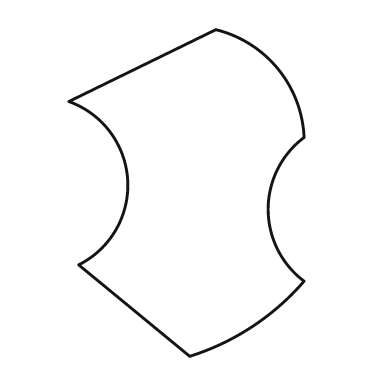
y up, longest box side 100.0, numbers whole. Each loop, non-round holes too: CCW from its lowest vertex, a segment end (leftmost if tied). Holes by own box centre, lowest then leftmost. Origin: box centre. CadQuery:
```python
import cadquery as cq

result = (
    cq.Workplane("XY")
    .moveTo(1.0, -50.0)
    .threePointArc((20.0, -41.0), (36.0, -27.0))
    .threePointArc((25.0, -5.0), (36.0, 17.0))
    .threePointArc((28.0, 38.0), (9.0, 50.0))
    .lineTo(-36.0, 28.0)
    .threePointArc((-18.0, 4.0), (-33.0, -22.0))
    .close()
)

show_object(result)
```